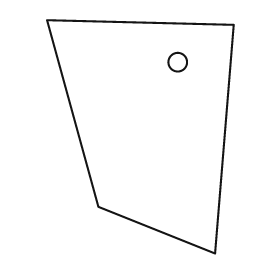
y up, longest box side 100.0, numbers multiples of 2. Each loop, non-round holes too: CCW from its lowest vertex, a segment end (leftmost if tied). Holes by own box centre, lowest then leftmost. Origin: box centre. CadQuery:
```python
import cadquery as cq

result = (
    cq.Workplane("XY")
    .moveTo(32.0, -50.0)
    .lineTo(40.0, 48.0)
    .lineTo(-40.0, 50.0)
    .lineTo(-18.0, -30.0)
    .close()
    .moveTo(16.0, 32.0)
    .circle(4.0)
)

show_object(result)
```